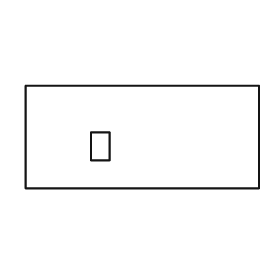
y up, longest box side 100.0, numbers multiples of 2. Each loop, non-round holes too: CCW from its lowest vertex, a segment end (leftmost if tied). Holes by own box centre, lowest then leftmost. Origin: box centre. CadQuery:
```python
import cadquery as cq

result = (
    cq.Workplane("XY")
    .moveTo(-50.0, -22.0)
    .lineTo(50.0, -22.0)
    .lineTo(50.0, 22.0)
    .lineTo(-50.0, 22.0)
    .close()
    .moveTo(-22.0, -10.0)
    .lineTo(-14.0, -10.0)
    .lineTo(-14.0, 2.0)
    .lineTo(-22.0, 2.0)
    .close()
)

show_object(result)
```